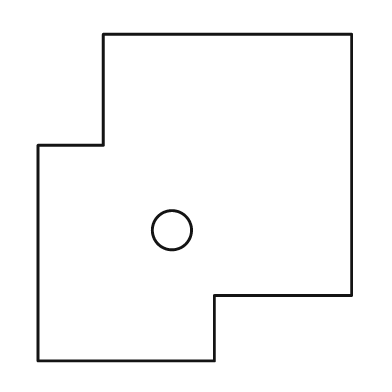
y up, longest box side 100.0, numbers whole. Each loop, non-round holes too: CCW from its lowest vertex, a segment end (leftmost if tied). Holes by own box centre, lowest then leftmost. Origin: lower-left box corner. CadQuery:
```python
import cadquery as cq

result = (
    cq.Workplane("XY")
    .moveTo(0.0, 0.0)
    .lineTo(54.0, 0.0)
    .lineTo(54.0, 20.0)
    .lineTo(96.0, 20.0)
    .lineTo(96.0, 100.0)
    .lineTo(20.0, 100.0)
    .lineTo(20.0, 66.0)
    .lineTo(0.0, 66.0)
    .close()
    .moveTo(41.0, 40.0)
    .circle(6.0)
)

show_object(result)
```